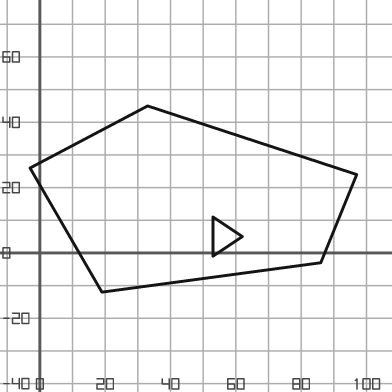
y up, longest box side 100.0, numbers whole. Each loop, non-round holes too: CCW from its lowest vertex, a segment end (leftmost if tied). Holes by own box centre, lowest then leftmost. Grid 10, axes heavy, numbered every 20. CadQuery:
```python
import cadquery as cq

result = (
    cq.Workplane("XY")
    .moveTo(19.0, -12.0)
    .lineTo(86.0, -3.0)
    .lineTo(97.0, 24.0)
    .lineTo(33.0, 45.0)
    .lineTo(-3.0, 26.0)
    .close()
    .moveTo(53.0, -1.0)
    .lineTo(62.0, 5.0)
    .lineTo(53.0, 11.0)
    .close()
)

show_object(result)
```